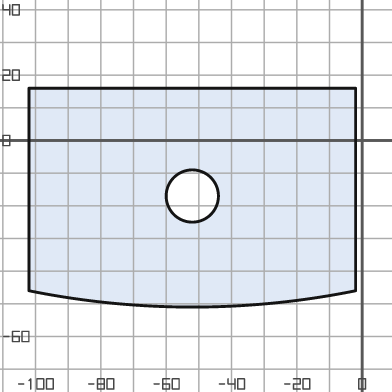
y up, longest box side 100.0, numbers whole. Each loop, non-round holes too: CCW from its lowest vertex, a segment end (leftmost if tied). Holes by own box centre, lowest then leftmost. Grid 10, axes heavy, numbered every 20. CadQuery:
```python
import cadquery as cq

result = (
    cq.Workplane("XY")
    .moveTo(-102.0, -46.0)
    .threePointArc((-52.0, -51.0), (-2.0, -46.0))
    .lineTo(-2.0, 16.0)
    .lineTo(-102.0, 16.0)
    .close()
    .moveTo(-52.0, -17.0)
    .circle(8.0)
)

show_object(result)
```